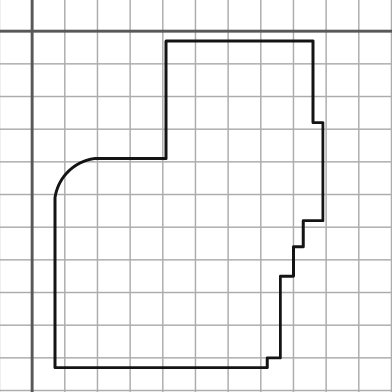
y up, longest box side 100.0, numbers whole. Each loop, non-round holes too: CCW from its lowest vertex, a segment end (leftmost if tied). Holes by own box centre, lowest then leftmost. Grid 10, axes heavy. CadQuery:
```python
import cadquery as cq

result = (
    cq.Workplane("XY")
    .moveTo(7.0, -103.0)
    .lineTo(72.0, -103.0)
    .lineTo(72.0, -100.0)
    .lineTo(76.0, -100.0)
    .lineTo(76.0, -75.0)
    .lineTo(80.0, -75.0)
    .lineTo(80.0, -66.0)
    .lineTo(83.0, -66.0)
    .lineTo(83.0, -58.0)
    .lineTo(89.0, -58.0)
    .lineTo(89.0, -28.0)
    .lineTo(86.0, -28.0)
    .lineTo(86.0, -3.0)
    .lineTo(41.0, -3.0)
    .lineTo(41.0, -39.0)
    .lineTo(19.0, -39.0)
    .threePointArc((11.0, -43.0), (7.0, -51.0))
    .close()
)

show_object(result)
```